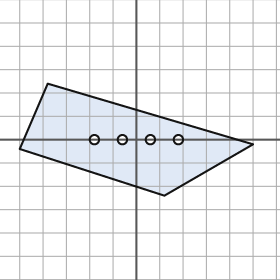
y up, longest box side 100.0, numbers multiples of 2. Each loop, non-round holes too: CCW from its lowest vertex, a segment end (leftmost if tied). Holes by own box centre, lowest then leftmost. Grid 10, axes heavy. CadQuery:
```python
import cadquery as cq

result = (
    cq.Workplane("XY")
    .moveTo(12.0, -24.0)
    .lineTo(50.0, -2.0)
    .lineTo(-38.0, 24.0)
    .lineTo(-50.0, -4.0)
    .close()
    .moveTo(-18.0, 0.0)
    .circle(2.0)
    .moveTo(-6.0, 0.0)
    .circle(2.0)
    .moveTo(6.0, 0.0)
    .circle(2.0)
    .moveTo(18.0, 0.0)
    .circle(2.0)
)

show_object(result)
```